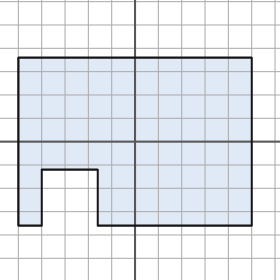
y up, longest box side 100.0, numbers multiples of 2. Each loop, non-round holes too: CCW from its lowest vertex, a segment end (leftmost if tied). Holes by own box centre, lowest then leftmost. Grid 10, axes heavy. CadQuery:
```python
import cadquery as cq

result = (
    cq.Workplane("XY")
    .moveTo(-50.0, -36.0)
    .lineTo(-40.0, -36.0)
    .lineTo(-40.0, -12.0)
    .lineTo(-16.0, -12.0)
    .lineTo(-16.0, -36.0)
    .lineTo(50.0, -36.0)
    .lineTo(50.0, 36.0)
    .lineTo(-50.0, 36.0)
    .close()
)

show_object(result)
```